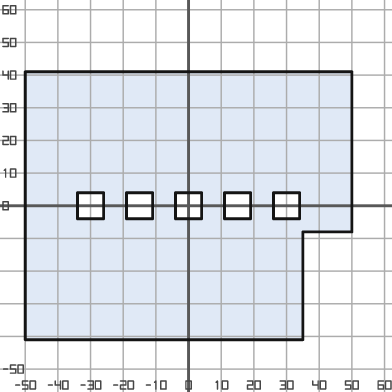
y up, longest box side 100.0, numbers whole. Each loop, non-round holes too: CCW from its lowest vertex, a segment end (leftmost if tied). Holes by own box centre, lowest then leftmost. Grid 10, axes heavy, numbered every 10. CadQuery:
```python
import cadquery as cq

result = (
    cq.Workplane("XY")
    .moveTo(-50.0, -41.0)
    .lineTo(35.0, -41.0)
    .lineTo(35.0, -8.0)
    .lineTo(50.0, -8.0)
    .lineTo(50.0, 41.0)
    .lineTo(-50.0, 41.0)
    .close()
    .moveTo(-34.0, -4.0)
    .lineTo(-26.0, -4.0)
    .lineTo(-26.0, 4.0)
    .lineTo(-34.0, 4.0)
    .close()
    .moveTo(-19.0, -4.0)
    .lineTo(-11.0, -4.0)
    .lineTo(-11.0, 4.0)
    .lineTo(-19.0, 4.0)
    .close()
    .moveTo(-4.0, -4.0)
    .lineTo(4.0, -4.0)
    .lineTo(4.0, 4.0)
    .lineTo(-4.0, 4.0)
    .close()
    .moveTo(11.0, -4.0)
    .lineTo(19.0, -4.0)
    .lineTo(19.0, 4.0)
    .lineTo(11.0, 4.0)
    .close()
    .moveTo(26.0, -4.0)
    .lineTo(34.0, -4.0)
    .lineTo(34.0, 4.0)
    .lineTo(26.0, 4.0)
    .close()
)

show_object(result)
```